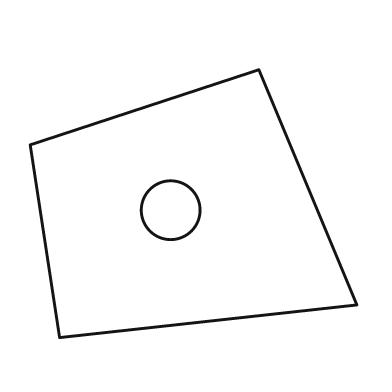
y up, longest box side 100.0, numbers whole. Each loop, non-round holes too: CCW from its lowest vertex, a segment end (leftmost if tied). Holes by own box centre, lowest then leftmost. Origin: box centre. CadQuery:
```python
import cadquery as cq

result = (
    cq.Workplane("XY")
    .moveTo(-41.0, -41.0)
    .lineTo(50.0, -31.0)
    .lineTo(20.0, 41.0)
    .lineTo(-50.0, 18.0)
    .close()
    .moveTo(-7.0, -2.0)
    .circle(9.0)
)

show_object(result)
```